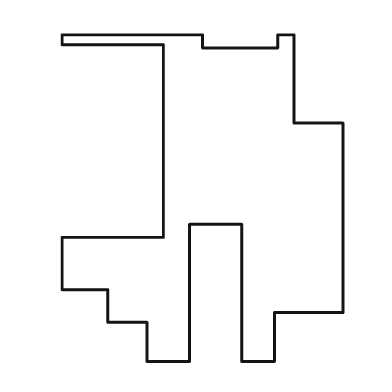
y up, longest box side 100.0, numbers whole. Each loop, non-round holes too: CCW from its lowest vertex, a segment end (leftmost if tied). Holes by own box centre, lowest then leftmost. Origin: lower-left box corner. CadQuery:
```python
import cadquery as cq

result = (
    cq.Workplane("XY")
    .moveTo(26.0, 0.0)
    .lineTo(39.0, 0.0)
    .lineTo(39.0, 42.0)
    .lineTo(55.0, 42.0)
    .lineTo(55.0, 0.0)
    .lineTo(65.0, 0.0)
    .lineTo(65.0, 15.0)
    .lineTo(86.0, 15.0)
    .lineTo(86.0, 73.0)
    .lineTo(71.0, 73.0)
    .lineTo(71.0, 100.0)
    .lineTo(66.0, 100.0)
    .lineTo(66.0, 96.0)
    .lineTo(43.0, 96.0)
    .lineTo(43.0, 100.0)
    .lineTo(0.0, 100.0)
    .lineTo(0.0, 97.0)
    .lineTo(31.0, 97.0)
    .lineTo(31.0, 38.0)
    .lineTo(0.0, 38.0)
    .lineTo(0.0, 22.0)
    .lineTo(14.0, 22.0)
    .lineTo(14.0, 12.0)
    .lineTo(26.0, 12.0)
    .close()
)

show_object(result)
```